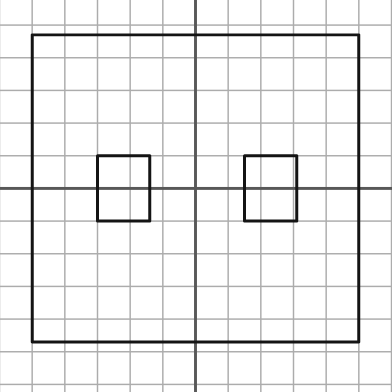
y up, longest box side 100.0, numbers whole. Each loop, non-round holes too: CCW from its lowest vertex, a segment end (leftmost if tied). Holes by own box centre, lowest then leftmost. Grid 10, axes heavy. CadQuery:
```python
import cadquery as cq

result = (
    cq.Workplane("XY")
    .moveTo(-50.0, -47.0)
    .lineTo(50.0, -47.0)
    .lineTo(50.0, 47.0)
    .lineTo(-50.0, 47.0)
    .close()
    .moveTo(-30.0, -10.0)
    .lineTo(-14.0, -10.0)
    .lineTo(-14.0, 10.0)
    .lineTo(-30.0, 10.0)
    .close()
    .moveTo(15.0, -10.0)
    .lineTo(31.0, -10.0)
    .lineTo(31.0, 10.0)
    .lineTo(15.0, 10.0)
    .close()
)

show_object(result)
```